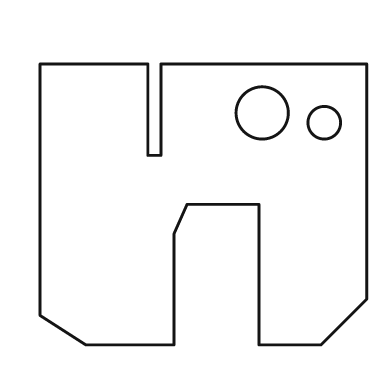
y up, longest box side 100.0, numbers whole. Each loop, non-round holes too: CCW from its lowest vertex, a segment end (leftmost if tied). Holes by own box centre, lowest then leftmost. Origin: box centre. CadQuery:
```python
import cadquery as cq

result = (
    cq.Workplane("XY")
    .moveTo(-36.0, -43.0)
    .lineTo(-9.0, -43.0)
    .lineTo(-9.0, -9.0)
    .lineTo(-5.0, 0.0)
    .lineTo(17.0, 0.0)
    .lineTo(17.0, -43.0)
    .lineTo(36.0, -43.0)
    .lineTo(50.0, -29.0)
    .lineTo(50.0, 43.0)
    .lineTo(-13.0, 43.0)
    .lineTo(-13.0, 15.0)
    .lineTo(-17.0, 15.0)
    .lineTo(-17.0, 43.0)
    .lineTo(-50.0, 43.0)
    .lineTo(-50.0, -34.0)
    .close()
    .moveTo(37.0, 25.0)
    .circle(5.0)
    .moveTo(18.0, 28.0)
    .circle(8.0)
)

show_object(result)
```